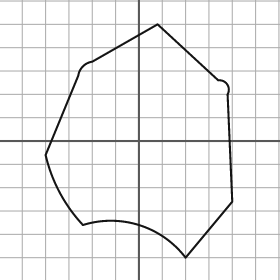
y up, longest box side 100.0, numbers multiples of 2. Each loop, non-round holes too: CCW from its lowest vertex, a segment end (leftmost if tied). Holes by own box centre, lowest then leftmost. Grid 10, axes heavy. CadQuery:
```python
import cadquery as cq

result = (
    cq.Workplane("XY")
    .moveTo(20.0, -50.0)
    .lineTo(40.0, -26.0)
    .lineTo(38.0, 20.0)
    .threePointArc((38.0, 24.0), (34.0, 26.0))
    .lineTo(8.0, 50.0)
    .lineTo(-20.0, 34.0)
    .threePointArc((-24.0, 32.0), (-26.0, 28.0))
    .lineTo(-40.0, -6.0)
    .threePointArc((-34.0, -22.0), (-24.0, -36.0))
    .threePointArc((0.0, -36.0), (20.0, -50.0))
    .close()
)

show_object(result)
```